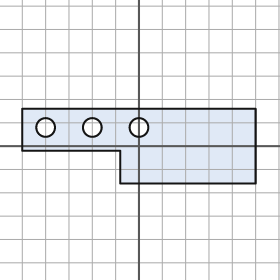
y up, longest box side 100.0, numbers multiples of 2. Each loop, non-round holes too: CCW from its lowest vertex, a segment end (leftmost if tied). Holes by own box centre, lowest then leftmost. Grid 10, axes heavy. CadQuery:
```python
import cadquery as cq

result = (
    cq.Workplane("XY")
    .moveTo(-8.0, -16.0)
    .lineTo(50.0, -16.0)
    .lineTo(50.0, 16.0)
    .lineTo(-50.0, 16.0)
    .lineTo(-50.0, -2.0)
    .lineTo(-8.0, -2.0)
    .close()
    .moveTo(-40.0, 8.0)
    .circle(4.0)
    .moveTo(-20.0, 8.0)
    .circle(4.0)
    .moveTo(0.0, 8.0)
    .circle(4.0)
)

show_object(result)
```